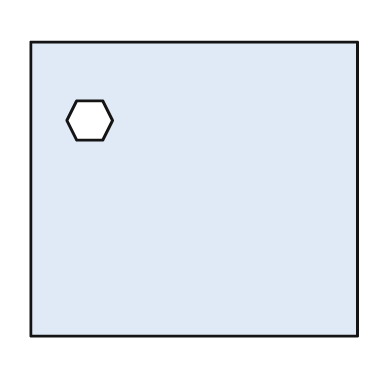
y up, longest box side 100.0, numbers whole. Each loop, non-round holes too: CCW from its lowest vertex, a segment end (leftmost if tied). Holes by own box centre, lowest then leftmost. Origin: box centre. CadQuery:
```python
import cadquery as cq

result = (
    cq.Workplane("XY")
    .moveTo(-50.0, -45.0)
    .lineTo(50.0, -45.0)
    .lineTo(50.0, 45.0)
    .lineTo(-50.0, 45.0)
    .close()
    .moveTo(-36.0, 15.0)
    .lineTo(-28.0, 15.0)
    .lineTo(-25.0, 21.0)
    .lineTo(-28.0, 27.0)
    .lineTo(-36.0, 27.0)
    .lineTo(-39.0, 21.0)
    .close()
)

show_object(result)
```